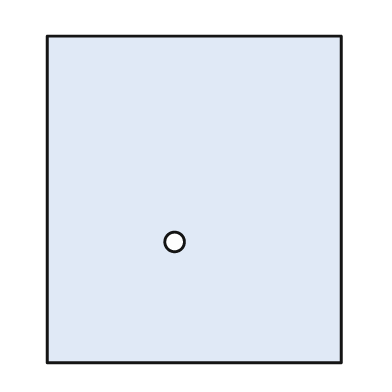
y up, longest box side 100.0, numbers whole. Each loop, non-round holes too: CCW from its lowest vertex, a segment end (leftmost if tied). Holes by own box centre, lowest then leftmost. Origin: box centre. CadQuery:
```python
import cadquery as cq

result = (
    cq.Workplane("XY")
    .moveTo(-45.0, -50.0)
    .lineTo(45.0, -50.0)
    .lineTo(45.0, 50.0)
    .lineTo(-45.0, 50.0)
    .close()
    .moveTo(-6.0, -13.0)
    .circle(3.0)
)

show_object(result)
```